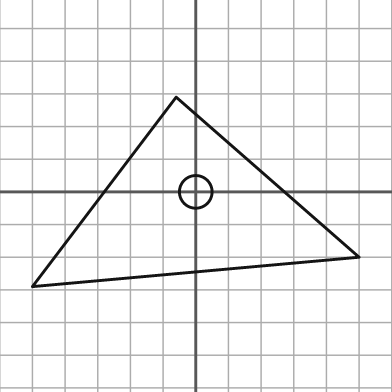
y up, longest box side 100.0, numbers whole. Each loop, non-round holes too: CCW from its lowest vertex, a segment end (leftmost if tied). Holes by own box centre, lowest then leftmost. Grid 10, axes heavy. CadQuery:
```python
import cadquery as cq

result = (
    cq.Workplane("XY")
    .moveTo(-50.0, -29.0)
    .lineTo(50.0, -20.0)
    .lineTo(-6.0, 29.0)
    .close()
    .moveTo(0.0, 0.0)
    .circle(5.0)
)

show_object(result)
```